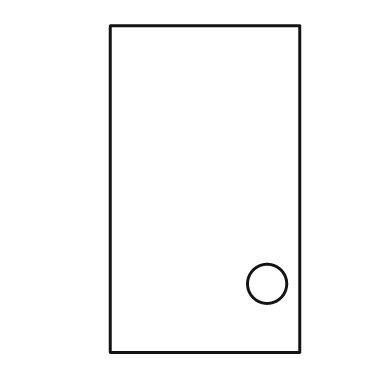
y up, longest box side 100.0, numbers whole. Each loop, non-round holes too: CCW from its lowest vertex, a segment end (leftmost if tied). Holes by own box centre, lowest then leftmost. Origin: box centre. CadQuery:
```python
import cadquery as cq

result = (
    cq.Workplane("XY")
    .moveTo(-29.0, -50.0)
    .lineTo(29.0, -50.0)
    .lineTo(29.0, 50.0)
    .lineTo(-29.0, 50.0)
    .close()
    .moveTo(19.0, -29.0)
    .circle(6.0)
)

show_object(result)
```